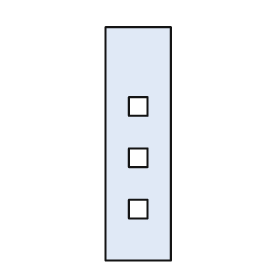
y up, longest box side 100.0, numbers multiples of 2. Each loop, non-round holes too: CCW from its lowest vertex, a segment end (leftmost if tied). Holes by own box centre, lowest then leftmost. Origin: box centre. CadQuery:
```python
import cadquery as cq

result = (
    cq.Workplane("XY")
    .moveTo(-14.0, -50.0)
    .lineTo(14.0, -50.0)
    .lineTo(14.0, 50.0)
    .lineTo(-14.0, 50.0)
    .close()
    .moveTo(-4.0, -32.0)
    .lineTo(4.0, -32.0)
    .lineTo(4.0, -24.0)
    .lineTo(-4.0, -24.0)
    .close()
    .moveTo(-4.0, -10.0)
    .lineTo(4.0, -10.0)
    .lineTo(4.0, -2.0)
    .lineTo(-4.0, -2.0)
    .close()
    .moveTo(-4.0, 12.0)
    .lineTo(4.0, 12.0)
    .lineTo(4.0, 20.0)
    .lineTo(-4.0, 20.0)
    .close()
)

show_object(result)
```